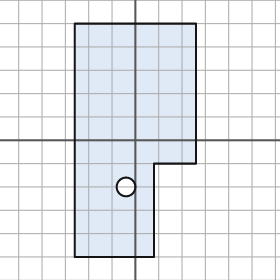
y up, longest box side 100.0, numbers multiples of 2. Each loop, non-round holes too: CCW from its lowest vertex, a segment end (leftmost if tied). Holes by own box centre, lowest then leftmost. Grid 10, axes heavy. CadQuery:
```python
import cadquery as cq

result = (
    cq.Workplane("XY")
    .moveTo(-26.0, -50.0)
    .lineTo(8.0, -50.0)
    .lineTo(8.0, -10.0)
    .lineTo(26.0, -10.0)
    .lineTo(26.0, 50.0)
    .lineTo(-26.0, 50.0)
    .close()
    .moveTo(-4.0, -20.0)
    .circle(4.0)
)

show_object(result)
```